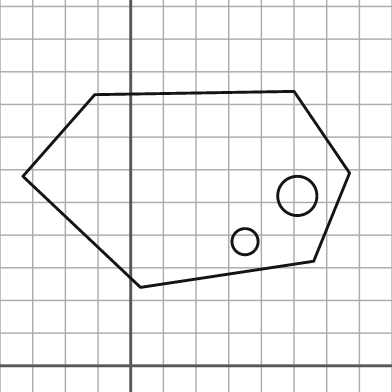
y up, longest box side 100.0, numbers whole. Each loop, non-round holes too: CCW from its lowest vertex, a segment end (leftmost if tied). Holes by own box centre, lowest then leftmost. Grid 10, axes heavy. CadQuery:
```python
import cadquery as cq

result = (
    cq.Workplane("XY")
    .moveTo(3.0, 24.0)
    .lineTo(56.0, 32.0)
    .lineTo(67.0, 59.0)
    .lineTo(50.0, 84.0)
    .lineTo(-11.0, 83.0)
    .lineTo(-33.0, 58.0)
    .close()
    .moveTo(35.0, 38.0)
    .circle(4.0)
    .moveTo(51.0, 52.0)
    .circle(6.0)
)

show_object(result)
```